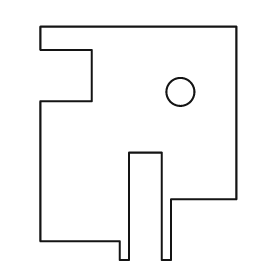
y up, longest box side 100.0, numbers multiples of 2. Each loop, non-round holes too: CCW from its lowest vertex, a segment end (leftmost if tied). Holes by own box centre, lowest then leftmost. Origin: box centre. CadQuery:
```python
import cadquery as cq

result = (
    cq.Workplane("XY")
    .moveTo(-8.0, -50.0)
    .lineTo(-4.0, -50.0)
    .lineTo(-4.0, -4.0)
    .lineTo(10.0, -4.0)
    .lineTo(10.0, -50.0)
    .lineTo(14.0, -50.0)
    .lineTo(14.0, -24.0)
    .lineTo(42.0, -24.0)
    .lineTo(42.0, 50.0)
    .lineTo(-42.0, 50.0)
    .lineTo(-42.0, 40.0)
    .lineTo(-20.0, 40.0)
    .lineTo(-20.0, 18.0)
    .lineTo(-42.0, 18.0)
    .lineTo(-42.0, -42.0)
    .lineTo(-8.0, -42.0)
    .close()
    .moveTo(18.0, 22.0)
    .circle(6.0)
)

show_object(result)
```